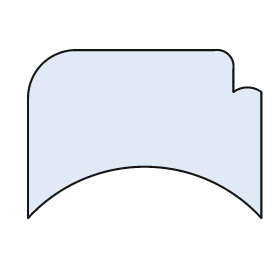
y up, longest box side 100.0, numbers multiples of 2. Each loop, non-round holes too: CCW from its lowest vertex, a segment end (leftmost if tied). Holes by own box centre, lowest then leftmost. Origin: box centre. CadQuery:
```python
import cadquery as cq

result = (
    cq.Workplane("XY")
    .moveTo(-50.0, -36.0)
    .threePointArc((0.0, -14.0), (50.0, -36.0))
    .lineTo(50.0, 18.0)
    .threePointArc((44.0, 20.0), (38.0, 18.0))
    .lineTo(38.0, 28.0)
    .threePointArc((36.0, 34.0), (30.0, 36.0))
    .lineTo(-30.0, 36.0)
    .threePointArc((-44.0, 30.0), (-50.0, 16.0))
    .close()
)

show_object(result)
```